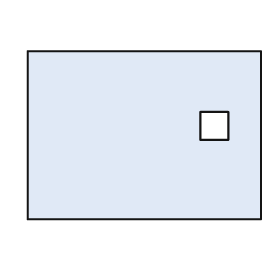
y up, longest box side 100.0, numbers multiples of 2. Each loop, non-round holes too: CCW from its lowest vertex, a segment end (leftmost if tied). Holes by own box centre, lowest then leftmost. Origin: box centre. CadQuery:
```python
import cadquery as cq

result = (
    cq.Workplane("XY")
    .moveTo(-50.0, -36.0)
    .lineTo(50.0, -36.0)
    .lineTo(50.0, 36.0)
    .lineTo(-50.0, 36.0)
    .close()
    .moveTo(24.0, -2.0)
    .lineTo(36.0, -2.0)
    .lineTo(36.0, 10.0)
    .lineTo(24.0, 10.0)
    .close()
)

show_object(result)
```